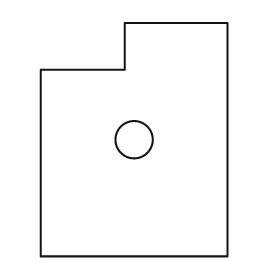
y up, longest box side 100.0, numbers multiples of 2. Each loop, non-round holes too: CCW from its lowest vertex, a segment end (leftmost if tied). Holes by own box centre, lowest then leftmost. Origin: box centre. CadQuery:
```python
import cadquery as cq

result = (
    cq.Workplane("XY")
    .moveTo(-40.0, -50.0)
    .lineTo(40.0, -50.0)
    .lineTo(40.0, 50.0)
    .lineTo(-4.0, 50.0)
    .lineTo(-4.0, 30.0)
    .lineTo(-40.0, 30.0)
    .close()
    .moveTo(0.0, 0.0)
    .circle(8.0)
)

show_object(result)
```